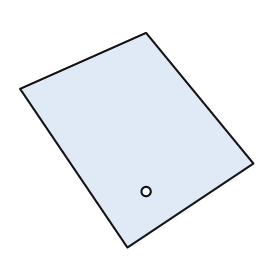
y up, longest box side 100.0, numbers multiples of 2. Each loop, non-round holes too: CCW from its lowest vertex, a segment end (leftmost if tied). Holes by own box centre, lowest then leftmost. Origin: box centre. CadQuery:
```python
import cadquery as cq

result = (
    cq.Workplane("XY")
    .moveTo(-4.0, -46.0)
    .lineTo(50.0, -10.0)
    .lineTo(4.0, 46.0)
    .lineTo(-50.0, 22.0)
    .close()
    .moveTo(4.0, -22.0)
    .circle(2.0)
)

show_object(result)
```